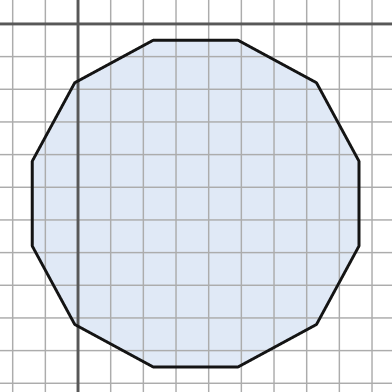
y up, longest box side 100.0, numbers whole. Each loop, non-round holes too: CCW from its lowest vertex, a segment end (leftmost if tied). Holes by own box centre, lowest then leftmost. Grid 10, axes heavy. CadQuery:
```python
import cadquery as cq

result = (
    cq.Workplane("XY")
    .moveTo(23.0, -105.0)
    .lineTo(49.0, -105.0)
    .lineTo(73.0, -92.0)
    .lineTo(86.0, -68.0)
    .lineTo(86.0, -42.0)
    .lineTo(73.0, -18.0)
    .lineTo(49.0, -5.0)
    .lineTo(23.0, -5.0)
    .lineTo(-1.0, -18.0)
    .lineTo(-14.0, -42.0)
    .lineTo(-14.0, -68.0)
    .lineTo(-1.0, -92.0)
    .close()
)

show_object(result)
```